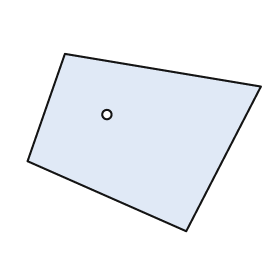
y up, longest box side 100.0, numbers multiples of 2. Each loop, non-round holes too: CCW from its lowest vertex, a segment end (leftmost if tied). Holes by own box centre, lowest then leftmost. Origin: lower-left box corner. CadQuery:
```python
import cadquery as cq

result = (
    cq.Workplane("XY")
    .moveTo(68.0, 0.0)
    .lineTo(100.0, 62.0)
    .lineTo(16.0, 76.0)
    .lineTo(0.0, 30.0)
    .close()
    .moveTo(34.0, 50.0)
    .circle(2.0)
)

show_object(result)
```